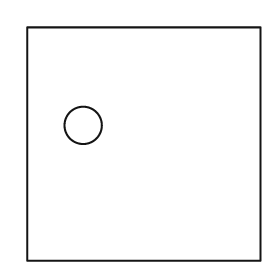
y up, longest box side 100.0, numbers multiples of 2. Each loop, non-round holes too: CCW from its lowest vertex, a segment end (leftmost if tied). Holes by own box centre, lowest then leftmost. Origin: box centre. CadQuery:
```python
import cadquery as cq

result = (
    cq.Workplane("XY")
    .moveTo(-50.0, -50.0)
    .lineTo(50.0, -50.0)
    .lineTo(50.0, 50.0)
    .lineTo(-50.0, 50.0)
    .close()
    .moveTo(-26.0, 8.0)
    .circle(8.0)
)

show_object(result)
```